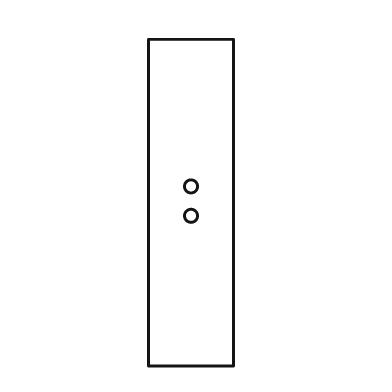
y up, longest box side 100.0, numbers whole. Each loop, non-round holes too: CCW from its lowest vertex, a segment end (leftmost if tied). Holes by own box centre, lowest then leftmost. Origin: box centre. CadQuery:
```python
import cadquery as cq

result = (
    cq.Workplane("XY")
    .moveTo(-13.0, -50.0)
    .lineTo(13.0, -50.0)
    .lineTo(13.0, 50.0)
    .lineTo(-13.0, 50.0)
    .close()
    .moveTo(0.0, -4.0)
    .circle(2.0)
    .moveTo(0.0, 5.0)
    .circle(2.0)
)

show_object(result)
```